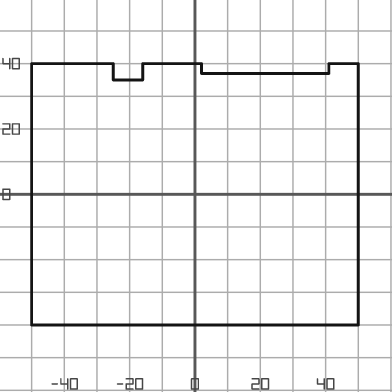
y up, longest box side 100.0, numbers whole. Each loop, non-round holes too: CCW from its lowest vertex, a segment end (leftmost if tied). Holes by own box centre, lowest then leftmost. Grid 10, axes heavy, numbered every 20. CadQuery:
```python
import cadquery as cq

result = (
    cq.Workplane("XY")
    .moveTo(-50.0, -40.0)
    .lineTo(50.0, -40.0)
    .lineTo(50.0, 40.0)
    .lineTo(41.0, 40.0)
    .lineTo(41.0, 37.0)
    .lineTo(2.0, 37.0)
    .lineTo(2.0, 40.0)
    .lineTo(-16.0, 40.0)
    .lineTo(-16.0, 35.0)
    .lineTo(-25.0, 35.0)
    .lineTo(-25.0, 40.0)
    .lineTo(-50.0, 40.0)
    .close()
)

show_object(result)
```